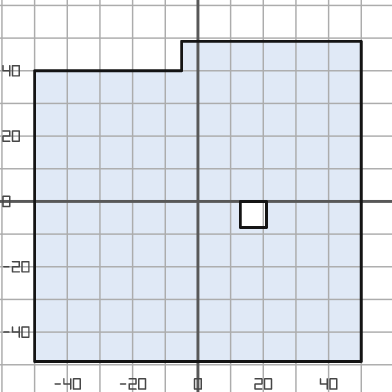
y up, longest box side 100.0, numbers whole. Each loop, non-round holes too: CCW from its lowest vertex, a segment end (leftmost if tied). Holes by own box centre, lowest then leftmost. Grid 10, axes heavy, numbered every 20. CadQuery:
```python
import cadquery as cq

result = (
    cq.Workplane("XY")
    .moveTo(-50.0, -49.0)
    .lineTo(50.0, -49.0)
    .lineTo(50.0, 49.0)
    .lineTo(-5.0, 49.0)
    .lineTo(-5.0, 40.0)
    .lineTo(-50.0, 40.0)
    .close()
    .moveTo(13.0, -8.0)
    .lineTo(21.0, -8.0)
    .lineTo(21.0, 0.0)
    .lineTo(13.0, 0.0)
    .close()
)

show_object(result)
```